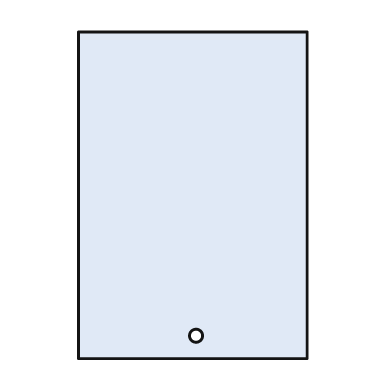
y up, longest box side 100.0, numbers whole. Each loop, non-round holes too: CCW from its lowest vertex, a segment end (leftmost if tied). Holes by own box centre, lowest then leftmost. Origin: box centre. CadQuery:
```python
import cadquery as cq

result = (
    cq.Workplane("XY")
    .moveTo(-35.0, -50.0)
    .lineTo(35.0, -50.0)
    .lineTo(35.0, 50.0)
    .lineTo(-35.0, 50.0)
    .close()
    .moveTo(1.0, -43.0)
    .circle(2.0)
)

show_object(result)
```